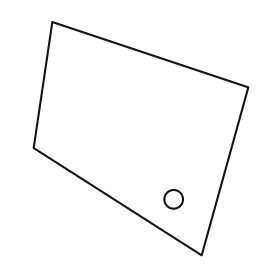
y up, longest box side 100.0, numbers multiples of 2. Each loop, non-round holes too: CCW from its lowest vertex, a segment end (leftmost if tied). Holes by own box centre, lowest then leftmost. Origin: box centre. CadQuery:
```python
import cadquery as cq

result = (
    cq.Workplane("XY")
    .moveTo(26.0, -50.0)
    .lineTo(46.0, 22.0)
    .lineTo(-38.0, 50.0)
    .lineTo(-46.0, -4.0)
    .close()
    .moveTo(14.0, -26.0)
    .circle(4.0)
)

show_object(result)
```